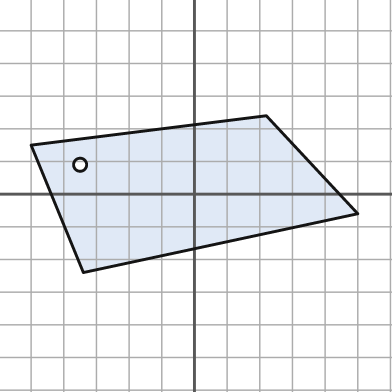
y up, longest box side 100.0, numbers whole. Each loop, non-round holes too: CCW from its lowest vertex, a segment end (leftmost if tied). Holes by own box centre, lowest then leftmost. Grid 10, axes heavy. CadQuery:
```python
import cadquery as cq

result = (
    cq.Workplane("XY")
    .moveTo(-34.0, -24.0)
    .lineTo(50.0, -6.0)
    .lineTo(22.0, 24.0)
    .lineTo(-50.0, 15.0)
    .close()
    .moveTo(-35.0, 9.0)
    .circle(2.0)
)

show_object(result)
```